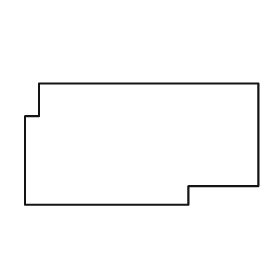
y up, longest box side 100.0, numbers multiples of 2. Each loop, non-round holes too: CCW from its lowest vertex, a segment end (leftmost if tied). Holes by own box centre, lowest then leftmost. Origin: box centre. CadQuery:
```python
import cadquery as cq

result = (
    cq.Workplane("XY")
    .moveTo(-50.0, -26.0)
    .lineTo(20.0, -26.0)
    .lineTo(20.0, -18.0)
    .lineTo(50.0, -18.0)
    .lineTo(50.0, 26.0)
    .lineTo(-44.0, 26.0)
    .lineTo(-44.0, 12.0)
    .lineTo(-50.0, 12.0)
    .close()
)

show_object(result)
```